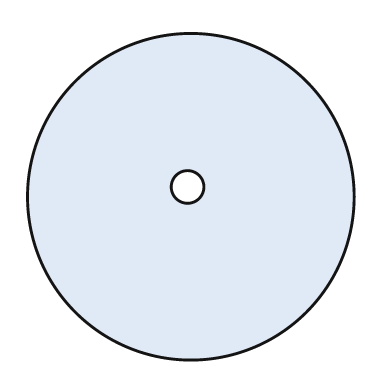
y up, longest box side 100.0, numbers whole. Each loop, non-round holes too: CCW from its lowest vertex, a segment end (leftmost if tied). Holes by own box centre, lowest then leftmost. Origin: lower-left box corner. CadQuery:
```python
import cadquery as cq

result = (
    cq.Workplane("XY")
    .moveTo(50.0, 50.0)
    .circle(50.0)
    .moveTo(49.0, 53.0)
    .circle(5.0)
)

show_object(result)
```